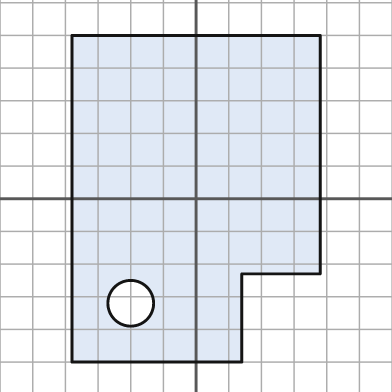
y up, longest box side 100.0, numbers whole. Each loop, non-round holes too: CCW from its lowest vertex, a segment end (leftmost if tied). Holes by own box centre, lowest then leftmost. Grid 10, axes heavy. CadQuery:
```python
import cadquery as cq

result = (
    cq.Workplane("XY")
    .moveTo(-38.0, -50.0)
    .lineTo(14.0, -50.0)
    .lineTo(14.0, -23.0)
    .lineTo(38.0, -23.0)
    .lineTo(38.0, 50.0)
    .lineTo(-38.0, 50.0)
    .close()
    .moveTo(-20.0, -32.0)
    .circle(7.0)
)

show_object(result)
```